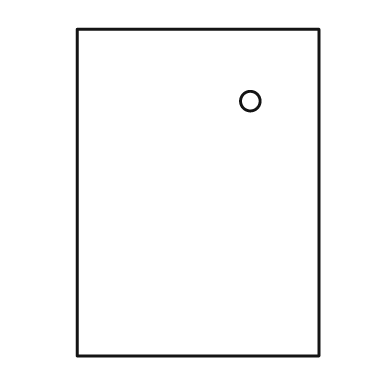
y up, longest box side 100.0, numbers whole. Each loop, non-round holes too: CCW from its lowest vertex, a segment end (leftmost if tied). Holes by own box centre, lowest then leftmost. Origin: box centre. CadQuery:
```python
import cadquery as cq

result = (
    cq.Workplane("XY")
    .moveTo(-37.0, -50.0)
    .lineTo(37.0, -50.0)
    .lineTo(37.0, 50.0)
    .lineTo(-37.0, 50.0)
    .close()
    .moveTo(16.0, 28.0)
    .circle(3.0)
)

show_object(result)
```